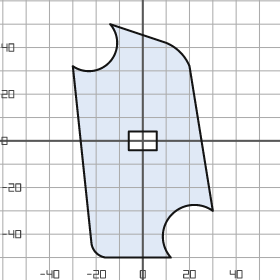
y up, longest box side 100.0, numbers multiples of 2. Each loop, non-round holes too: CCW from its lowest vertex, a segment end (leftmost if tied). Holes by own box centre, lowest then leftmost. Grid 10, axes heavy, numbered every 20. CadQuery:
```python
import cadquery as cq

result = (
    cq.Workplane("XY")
    .moveTo(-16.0, -50.0)
    .lineTo(12.0, -50.0)
    .threePointArc((12.0, -32.0), (30.0, -30.0))
    .lineTo(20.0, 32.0)
    .threePointArc((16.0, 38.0), (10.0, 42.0))
    .lineTo(-14.0, 50.0)
    .threePointArc((-14.0, 34.0), (-30.0, 32.0))
    .lineTo(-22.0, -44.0)
    .threePointArc((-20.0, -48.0), (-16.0, -50.0))
    .close()
    .moveTo(-6.0, -4.0)
    .lineTo(6.0, -4.0)
    .lineTo(6.0, 4.0)
    .lineTo(-6.0, 4.0)
    .close()
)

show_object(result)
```